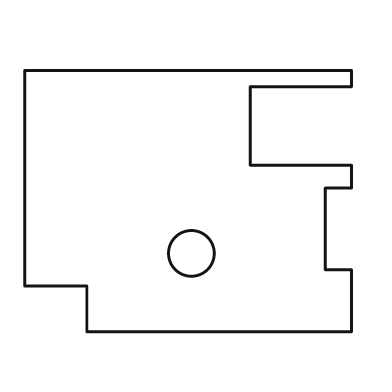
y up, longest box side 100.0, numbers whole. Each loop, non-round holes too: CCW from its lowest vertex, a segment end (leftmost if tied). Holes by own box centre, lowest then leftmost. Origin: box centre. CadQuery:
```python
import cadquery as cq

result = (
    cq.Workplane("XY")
    .moveTo(-31.0, -40.0)
    .lineTo(50.0, -40.0)
    .lineTo(50.0, -21.0)
    .lineTo(42.0, -21.0)
    .lineTo(42.0, 4.0)
    .lineTo(50.0, 4.0)
    .lineTo(50.0, 11.0)
    .lineTo(19.0, 11.0)
    .lineTo(19.0, 35.0)
    .lineTo(50.0, 35.0)
    .lineTo(50.0, 40.0)
    .lineTo(-50.0, 40.0)
    .lineTo(-50.0, -26.0)
    .lineTo(-31.0, -26.0)
    .close()
    .moveTo(1.0, -16.0)
    .circle(7.0)
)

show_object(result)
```